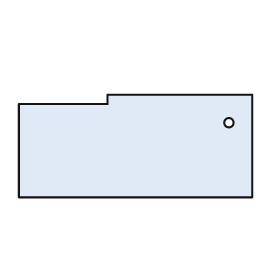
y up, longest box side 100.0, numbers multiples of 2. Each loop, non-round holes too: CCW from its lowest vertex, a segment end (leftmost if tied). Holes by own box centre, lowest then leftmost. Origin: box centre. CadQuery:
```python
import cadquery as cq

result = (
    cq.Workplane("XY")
    .moveTo(-50.0, -22.0)
    .lineTo(50.0, -22.0)
    .lineTo(50.0, 22.0)
    .lineTo(-12.0, 22.0)
    .lineTo(-12.0, 18.0)
    .lineTo(-50.0, 18.0)
    .close()
    .moveTo(40.0, 10.0)
    .circle(2.0)
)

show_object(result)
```